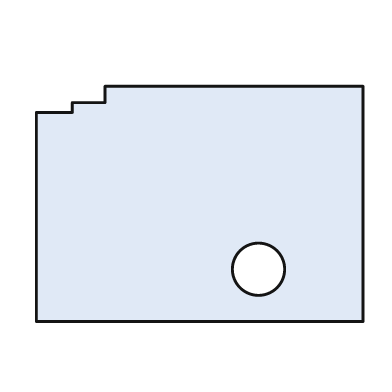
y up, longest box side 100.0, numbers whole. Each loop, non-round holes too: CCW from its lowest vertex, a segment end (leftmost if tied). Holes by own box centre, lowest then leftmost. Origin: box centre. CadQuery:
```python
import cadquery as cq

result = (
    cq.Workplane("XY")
    .moveTo(-50.0, -36.0)
    .lineTo(50.0, -36.0)
    .lineTo(50.0, 36.0)
    .lineTo(-29.0, 36.0)
    .lineTo(-29.0, 31.0)
    .lineTo(-39.0, 31.0)
    .lineTo(-39.0, 28.0)
    .lineTo(-50.0, 28.0)
    .close()
    .moveTo(18.0, -20.0)
    .circle(8.0)
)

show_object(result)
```